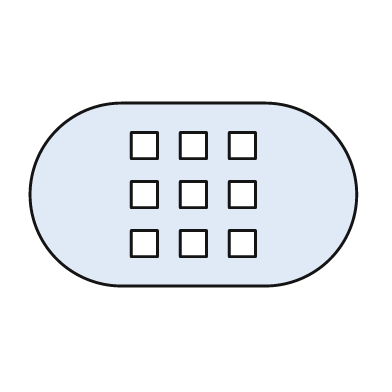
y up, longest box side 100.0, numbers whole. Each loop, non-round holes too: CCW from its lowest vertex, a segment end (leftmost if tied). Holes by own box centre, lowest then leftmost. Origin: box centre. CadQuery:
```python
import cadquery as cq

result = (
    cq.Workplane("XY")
    .moveTo(-22.0, -28.0)
    .lineTo(22.0, -28.0)
    .threePointArc((50.0, 0.0), (22.0, 28.0))
    .lineTo(-22.0, 28.0)
    .threePointArc((-50.0, 0.0), (-22.0, -28.0))
    .close()
    .moveTo(-19.0, -19.0)
    .lineTo(-11.0, -19.0)
    .lineTo(-11.0, -11.0)
    .lineTo(-19.0, -11.0)
    .close()
    .moveTo(-4.0, -19.0)
    .lineTo(4.0, -19.0)
    .lineTo(4.0, -11.0)
    .lineTo(-4.0, -11.0)
    .close()
    .moveTo(11.0, -19.0)
    .lineTo(19.0, -19.0)
    .lineTo(19.0, -11.0)
    .lineTo(11.0, -11.0)
    .close()
    .moveTo(-19.0, -4.0)
    .lineTo(-11.0, -4.0)
    .lineTo(-11.0, 4.0)
    .lineTo(-19.0, 4.0)
    .close()
    .moveTo(-4.0, -4.0)
    .lineTo(4.0, -4.0)
    .lineTo(4.0, 4.0)
    .lineTo(-4.0, 4.0)
    .close()
    .moveTo(11.0, -4.0)
    .lineTo(19.0, -4.0)
    .lineTo(19.0, 4.0)
    .lineTo(11.0, 4.0)
    .close()
    .moveTo(-19.0, 11.0)
    .lineTo(-11.0, 11.0)
    .lineTo(-11.0, 19.0)
    .lineTo(-19.0, 19.0)
    .close()
    .moveTo(-4.0, 11.0)
    .lineTo(4.0, 11.0)
    .lineTo(4.0, 19.0)
    .lineTo(-4.0, 19.0)
    .close()
    .moveTo(11.0, 11.0)
    .lineTo(19.0, 11.0)
    .lineTo(19.0, 19.0)
    .lineTo(11.0, 19.0)
    .close()
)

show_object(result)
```